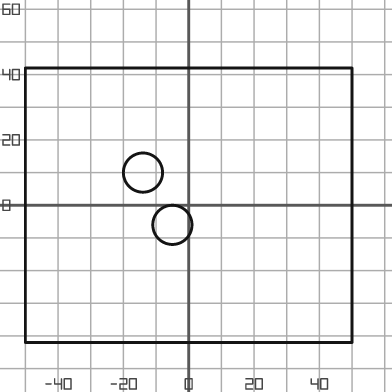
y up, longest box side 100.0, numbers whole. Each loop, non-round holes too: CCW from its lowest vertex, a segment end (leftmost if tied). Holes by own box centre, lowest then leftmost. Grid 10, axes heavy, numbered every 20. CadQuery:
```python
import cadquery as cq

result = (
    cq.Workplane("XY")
    .moveTo(-50.0, -42.0)
    .lineTo(50.0, -42.0)
    .lineTo(50.0, 42.0)
    .lineTo(-50.0, 42.0)
    .close()
    .moveTo(-5.0, -6.0)
    .circle(6.0)
    .moveTo(-14.0, 10.0)
    .circle(6.0)
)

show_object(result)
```